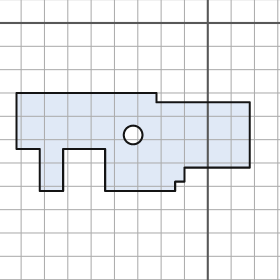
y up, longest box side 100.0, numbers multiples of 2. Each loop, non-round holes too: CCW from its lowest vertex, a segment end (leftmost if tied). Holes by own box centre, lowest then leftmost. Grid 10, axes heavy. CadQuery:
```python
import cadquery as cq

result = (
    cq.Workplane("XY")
    .moveTo(-72.0, -72.0)
    .lineTo(-62.0, -72.0)
    .lineTo(-62.0, -54.0)
    .lineTo(-44.0, -54.0)
    .lineTo(-44.0, -72.0)
    .lineTo(-14.0, -72.0)
    .lineTo(-14.0, -68.0)
    .lineTo(-10.0, -68.0)
    .lineTo(-10.0, -62.0)
    .lineTo(18.0, -62.0)
    .lineTo(18.0, -34.0)
    .lineTo(-22.0, -34.0)
    .lineTo(-22.0, -30.0)
    .lineTo(-82.0, -30.0)
    .lineTo(-82.0, -54.0)
    .lineTo(-72.0, -54.0)
    .close()
    .moveTo(-32.0, -48.0)
    .circle(4.0)
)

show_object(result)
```